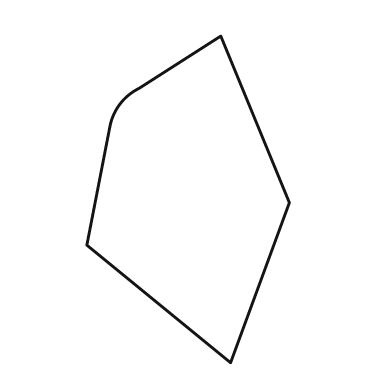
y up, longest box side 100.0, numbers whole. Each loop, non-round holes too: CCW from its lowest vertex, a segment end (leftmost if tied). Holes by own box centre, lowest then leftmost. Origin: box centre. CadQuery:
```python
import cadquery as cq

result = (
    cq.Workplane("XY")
    .moveTo(13.0, -50.0)
    .lineTo(31.0, -1.0)
    .lineTo(10.0, 50.0)
    .lineTo(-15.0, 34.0)
    .threePointArc((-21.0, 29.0), (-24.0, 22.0))
    .lineTo(-31.0, -14.0)
    .close()
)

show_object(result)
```